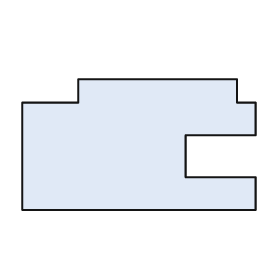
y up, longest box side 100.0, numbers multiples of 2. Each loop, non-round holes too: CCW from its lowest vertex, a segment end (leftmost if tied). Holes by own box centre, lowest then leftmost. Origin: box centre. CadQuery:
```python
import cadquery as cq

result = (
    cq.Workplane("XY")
    .moveTo(-50.0, -28.0)
    .lineTo(50.0, -28.0)
    .lineTo(50.0, -14.0)
    .lineTo(20.0, -14.0)
    .lineTo(20.0, 4.0)
    .lineTo(50.0, 4.0)
    .lineTo(50.0, 18.0)
    .lineTo(42.0, 18.0)
    .lineTo(42.0, 28.0)
    .lineTo(-26.0, 28.0)
    .lineTo(-26.0, 18.0)
    .lineTo(-50.0, 18.0)
    .close()
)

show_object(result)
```